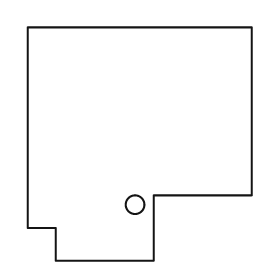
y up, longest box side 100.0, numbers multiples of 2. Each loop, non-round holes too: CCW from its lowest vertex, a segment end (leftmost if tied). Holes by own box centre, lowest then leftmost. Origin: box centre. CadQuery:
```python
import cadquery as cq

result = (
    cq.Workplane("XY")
    .moveTo(-36.0, -50.0)
    .lineTo(6.0, -50.0)
    .lineTo(6.0, -22.0)
    .lineTo(48.0, -22.0)
    .lineTo(48.0, 50.0)
    .lineTo(-48.0, 50.0)
    .lineTo(-48.0, -36.0)
    .lineTo(-36.0, -36.0)
    .close()
    .moveTo(-2.0, -26.0)
    .circle(4.0)
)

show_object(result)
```